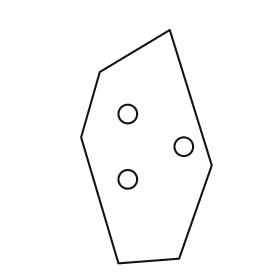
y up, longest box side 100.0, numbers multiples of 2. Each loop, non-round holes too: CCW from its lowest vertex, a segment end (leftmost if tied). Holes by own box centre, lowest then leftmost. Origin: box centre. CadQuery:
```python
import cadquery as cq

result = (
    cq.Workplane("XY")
    .moveTo(-12.0, -50.0)
    .lineTo(14.0, -48.0)
    .lineTo(28.0, -8.0)
    .lineTo(10.0, 50.0)
    .lineTo(-20.0, 32.0)
    .lineTo(-28.0, 4.0)
    .close()
    .moveTo(-8.0, -14.0)
    .circle(4.0)
    .moveTo(16.0, 0.0)
    .circle(4.0)
    .moveTo(-8.0, 14.0)
    .circle(4.0)
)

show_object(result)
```